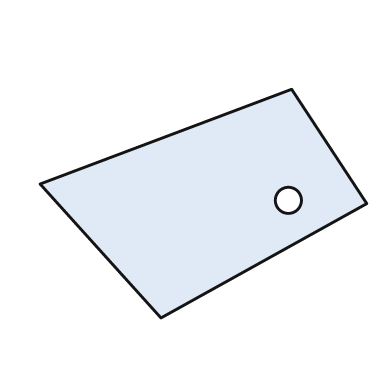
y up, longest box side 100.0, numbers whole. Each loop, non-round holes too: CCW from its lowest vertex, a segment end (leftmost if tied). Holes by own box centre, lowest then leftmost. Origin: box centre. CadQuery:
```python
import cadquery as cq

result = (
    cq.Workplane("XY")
    .moveTo(-13.0, -35.0)
    .lineTo(50.0, 0.0)
    .lineTo(27.0, 35.0)
    .lineTo(-50.0, 6.0)
    .close()
    .moveTo(26.0, 1.0)
    .circle(4.0)
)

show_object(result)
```